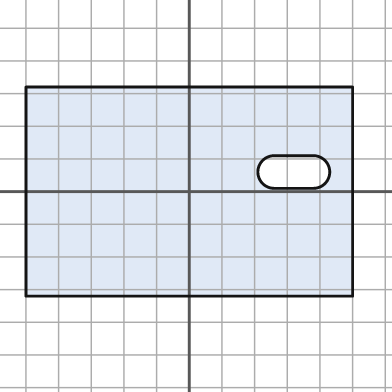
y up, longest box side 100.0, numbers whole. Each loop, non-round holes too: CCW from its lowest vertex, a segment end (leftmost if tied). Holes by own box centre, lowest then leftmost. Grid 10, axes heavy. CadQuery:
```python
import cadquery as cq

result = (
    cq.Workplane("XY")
    .moveTo(-50.0, -32.0)
    .lineTo(50.0, -32.0)
    .lineTo(50.0, 32.0)
    .lineTo(-50.0, 32.0)
    .close()
    .moveTo(26.0, 1.0)
    .lineTo(38.0, 1.0)
    .threePointArc((43.0, 6.0), (38.0, 11.0))
    .lineTo(26.0, 11.0)
    .threePointArc((21.0, 6.0), (26.0, 1.0))
    .close()
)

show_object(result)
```